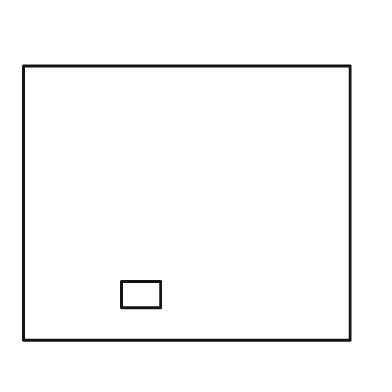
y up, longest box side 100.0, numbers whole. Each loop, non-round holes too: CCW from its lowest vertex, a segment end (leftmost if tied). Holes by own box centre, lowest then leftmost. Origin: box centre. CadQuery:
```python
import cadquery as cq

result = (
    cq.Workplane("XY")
    .moveTo(-50.0, -42.0)
    .lineTo(50.0, -42.0)
    .lineTo(50.0, 42.0)
    .lineTo(-50.0, 42.0)
    .close()
    .moveTo(-20.0, -32.0)
    .lineTo(-8.0, -32.0)
    .lineTo(-8.0, -24.0)
    .lineTo(-20.0, -24.0)
    .close()
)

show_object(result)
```